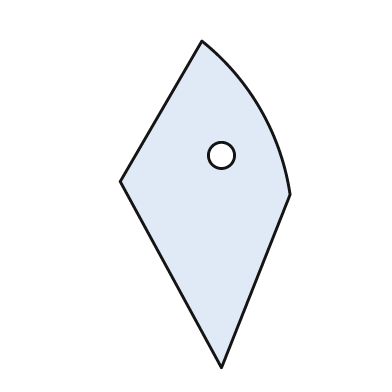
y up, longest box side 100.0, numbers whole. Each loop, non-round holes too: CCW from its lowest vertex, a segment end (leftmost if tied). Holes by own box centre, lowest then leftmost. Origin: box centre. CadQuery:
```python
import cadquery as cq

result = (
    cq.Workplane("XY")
    .moveTo(5.0, -50.0)
    .lineTo(26.0, 3.0)
    .threePointArc((17.0, 29.0), (-1.0, 50.0))
    .lineTo(-26.0, 7.0)
    .close()
    .moveTo(5.0, 15.0)
    .circle(4.0)
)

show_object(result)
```